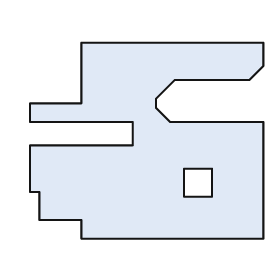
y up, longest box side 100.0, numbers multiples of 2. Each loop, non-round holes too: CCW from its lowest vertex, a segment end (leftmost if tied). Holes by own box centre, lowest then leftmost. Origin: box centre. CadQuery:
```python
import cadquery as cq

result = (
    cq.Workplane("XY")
    .moveTo(-28.0, -42.0)
    .lineTo(50.0, -42.0)
    .lineTo(50.0, 8.0)
    .lineTo(10.0, 8.0)
    .lineTo(4.0, 14.0)
    .lineTo(4.0, 18.0)
    .lineTo(12.0, 26.0)
    .lineTo(44.0, 26.0)
    .lineTo(50.0, 32.0)
    .lineTo(50.0, 42.0)
    .lineTo(-28.0, 42.0)
    .lineTo(-28.0, 16.0)
    .lineTo(-50.0, 16.0)
    .lineTo(-50.0, 8.0)
    .lineTo(-6.0, 8.0)
    .lineTo(-6.0, -2.0)
    .lineTo(-50.0, -2.0)
    .lineTo(-50.0, -22.0)
    .lineTo(-46.0, -22.0)
    .lineTo(-46.0, -34.0)
    .lineTo(-28.0, -34.0)
    .close()
    .moveTo(16.0, -24.0)
    .lineTo(28.0, -24.0)
    .lineTo(28.0, -12.0)
    .lineTo(16.0, -12.0)
    .close()
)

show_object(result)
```